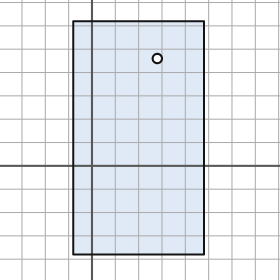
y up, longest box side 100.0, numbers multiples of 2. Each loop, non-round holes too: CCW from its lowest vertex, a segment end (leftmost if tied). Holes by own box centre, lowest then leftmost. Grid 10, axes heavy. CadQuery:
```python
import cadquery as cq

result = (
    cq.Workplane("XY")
    .moveTo(-8.0, -38.0)
    .lineTo(48.0, -38.0)
    .lineTo(48.0, 62.0)
    .lineTo(-8.0, 62.0)
    .close()
    .moveTo(28.0, 46.0)
    .circle(2.0)
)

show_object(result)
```